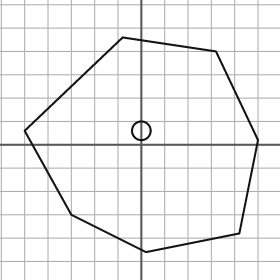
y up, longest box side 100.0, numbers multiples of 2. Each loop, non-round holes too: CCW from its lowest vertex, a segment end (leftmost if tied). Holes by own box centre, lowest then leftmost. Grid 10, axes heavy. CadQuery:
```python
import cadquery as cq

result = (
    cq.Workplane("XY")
    .moveTo(2.0, -46.0)
    .lineTo(42.0, -38.0)
    .lineTo(50.0, 2.0)
    .lineTo(32.0, 40.0)
    .lineTo(-8.0, 46.0)
    .lineTo(-50.0, 6.0)
    .lineTo(-30.0, -30.0)
    .close()
    .moveTo(0.0, 6.0)
    .circle(4.0)
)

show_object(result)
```